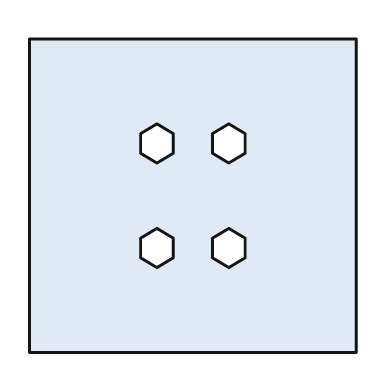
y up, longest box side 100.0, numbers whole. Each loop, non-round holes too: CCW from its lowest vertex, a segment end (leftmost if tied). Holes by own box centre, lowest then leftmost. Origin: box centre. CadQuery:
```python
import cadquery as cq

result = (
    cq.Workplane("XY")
    .moveTo(-50.0, -48.0)
    .lineTo(50.0, -48.0)
    .lineTo(50.0, 48.0)
    .lineTo(-50.0, 48.0)
    .close()
    .moveTo(-11.0, -22.0)
    .lineTo(-6.0, -19.0)
    .lineTo(-6.0, -13.0)
    .lineTo(-11.0, -10.0)
    .lineTo(-16.0, -13.0)
    .lineTo(-16.0, -19.0)
    .close()
    .moveTo(11.0, -22.0)
    .lineTo(16.0, -19.0)
    .lineTo(16.0, -13.0)
    .lineTo(11.0, -10.0)
    .lineTo(6.0, -13.0)
    .lineTo(6.0, -19.0)
    .close()
    .moveTo(-11.0, 10.0)
    .lineTo(-6.0, 13.0)
    .lineTo(-6.0, 19.0)
    .lineTo(-11.0, 22.0)
    .lineTo(-16.0, 19.0)
    .lineTo(-16.0, 13.0)
    .close()
    .moveTo(11.0, 10.0)
    .lineTo(16.0, 13.0)
    .lineTo(16.0, 19.0)
    .lineTo(11.0, 22.0)
    .lineTo(6.0, 19.0)
    .lineTo(6.0, 13.0)
    .close()
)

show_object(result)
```